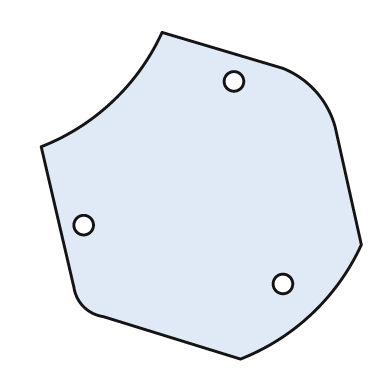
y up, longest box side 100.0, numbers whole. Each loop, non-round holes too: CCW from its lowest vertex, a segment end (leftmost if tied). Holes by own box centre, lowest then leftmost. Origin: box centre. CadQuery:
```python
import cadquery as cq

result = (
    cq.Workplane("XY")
    .moveTo(12.0, -50.0)
    .threePointArc((34.0, -36.0), (49.0, -15.0))
    .lineTo(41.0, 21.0)
    .threePointArc((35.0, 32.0), (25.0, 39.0))
    .lineTo(-12.0, 50.0)
    .threePointArc((-27.0, 29.0), (-49.0, 15.0))
    .lineTo(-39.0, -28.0)
    .threePointArc((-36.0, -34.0), (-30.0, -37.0))
    .close()
    .moveTo(25.0, -27.0)
    .circle(3.0)
    .moveTo(-36.0, -9.0)
    .circle(3.0)
    .moveTo(10.0, 35.0)
    .circle(3.0)
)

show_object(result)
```